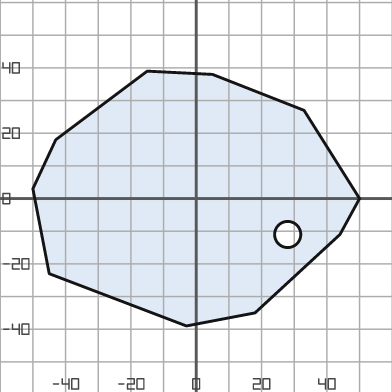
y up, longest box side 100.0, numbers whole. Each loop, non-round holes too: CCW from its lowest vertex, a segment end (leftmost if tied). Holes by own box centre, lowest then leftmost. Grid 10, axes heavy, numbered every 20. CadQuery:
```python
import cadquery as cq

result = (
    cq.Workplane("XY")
    .moveTo(-3.0, -39.0)
    .lineTo(18.0, -35.0)
    .lineTo(44.0, -11.0)
    .lineTo(50.0, 0.0)
    .lineTo(33.0, 27.0)
    .lineTo(5.0, 38.0)
    .lineTo(-15.0, 39.0)
    .lineTo(-43.0, 18.0)
    .lineTo(-50.0, 3.0)
    .lineTo(-45.0, -23.0)
    .close()
    .moveTo(28.0, -11.0)
    .circle(4.0)
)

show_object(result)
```